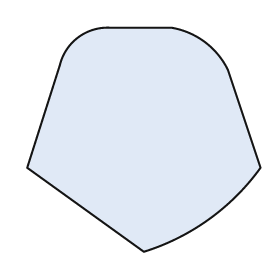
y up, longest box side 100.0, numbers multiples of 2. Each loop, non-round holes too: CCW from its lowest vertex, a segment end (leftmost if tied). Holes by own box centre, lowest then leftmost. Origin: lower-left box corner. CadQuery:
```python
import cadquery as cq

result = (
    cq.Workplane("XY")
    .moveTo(50.0, 0.0)
    .threePointArc((78.0, 14.0), (100.0, 36.0))
    .lineTo(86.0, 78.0)
    .threePointArc((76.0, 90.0), (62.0, 96.0))
    .lineTo(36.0, 96.0)
    .threePointArc((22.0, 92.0), (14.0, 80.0))
    .lineTo(0.0, 36.0)
    .close()
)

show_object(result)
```